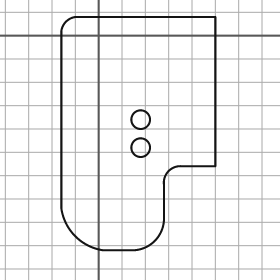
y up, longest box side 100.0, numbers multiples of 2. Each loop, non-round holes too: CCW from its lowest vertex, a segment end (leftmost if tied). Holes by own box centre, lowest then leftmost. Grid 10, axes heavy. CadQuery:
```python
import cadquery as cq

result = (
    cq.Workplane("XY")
    .moveTo(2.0, -92.0)
    .lineTo(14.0, -92.0)
    .threePointArc((24.0, -88.0), (28.0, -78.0))
    .lineTo(28.0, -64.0)
    .threePointArc((30.0, -58.0), (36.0, -56.0))
    .lineTo(50.0, -56.0)
    .lineTo(50.0, 8.0)
    .lineTo(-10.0, 8.0)
    .threePointArc((-14.0, 6.0), (-16.0, 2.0))
    .lineTo(-16.0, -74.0)
    .threePointArc((-10.0, -86.0), (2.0, -92.0))
    .close()
    .moveTo(18.0, -48.0)
    .circle(4.0)
    .moveTo(18.0, -36.0)
    .circle(4.0)
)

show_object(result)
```